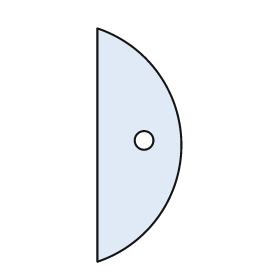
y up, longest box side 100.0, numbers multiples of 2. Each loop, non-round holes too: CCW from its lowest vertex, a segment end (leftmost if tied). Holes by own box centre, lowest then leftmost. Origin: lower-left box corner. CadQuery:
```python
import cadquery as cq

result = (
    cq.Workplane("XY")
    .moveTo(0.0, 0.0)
    .threePointArc((36.0, 50.0), (0.0, 100.0))
    .close()
    .moveTo(20.0, 52.0)
    .circle(4.0)
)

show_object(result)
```